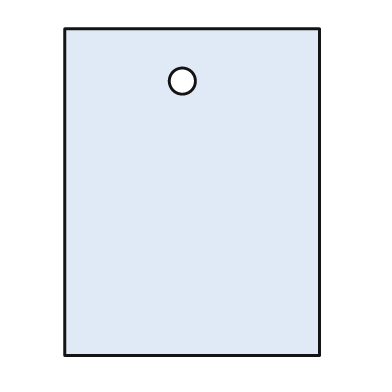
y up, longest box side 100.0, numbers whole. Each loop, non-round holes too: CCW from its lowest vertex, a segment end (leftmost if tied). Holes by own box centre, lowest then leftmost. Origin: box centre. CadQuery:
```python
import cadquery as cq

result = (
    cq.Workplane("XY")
    .moveTo(-39.0, -50.0)
    .lineTo(39.0, -50.0)
    .lineTo(39.0, 50.0)
    .lineTo(-39.0, 50.0)
    .close()
    .moveTo(-3.0, 34.0)
    .circle(4.0)
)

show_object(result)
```